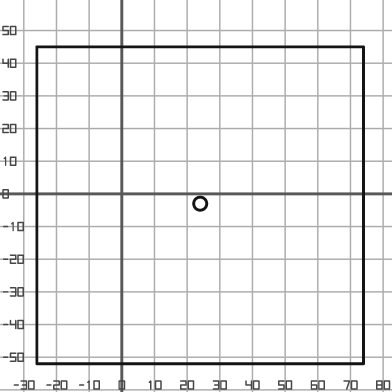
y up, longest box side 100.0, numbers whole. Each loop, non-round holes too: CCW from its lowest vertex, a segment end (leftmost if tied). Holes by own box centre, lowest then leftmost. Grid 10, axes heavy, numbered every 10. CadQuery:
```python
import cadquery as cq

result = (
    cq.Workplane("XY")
    .moveTo(-26.0, -52.0)
    .lineTo(74.0, -52.0)
    .lineTo(74.0, 45.0)
    .lineTo(-26.0, 45.0)
    .close()
    .moveTo(24.0, -3.0)
    .circle(2.0)
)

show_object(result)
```